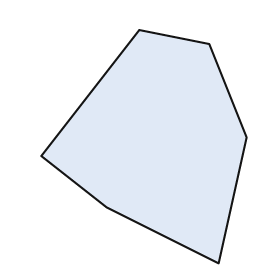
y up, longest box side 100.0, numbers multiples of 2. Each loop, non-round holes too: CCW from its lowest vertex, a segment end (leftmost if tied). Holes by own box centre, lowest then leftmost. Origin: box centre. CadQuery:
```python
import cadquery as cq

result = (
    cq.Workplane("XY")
    .moveTo(32.0, -50.0)
    .lineTo(44.0, 4.0)
    .lineTo(28.0, 44.0)
    .lineTo(-2.0, 50.0)
    .lineTo(-44.0, -4.0)
    .lineTo(-16.0, -26.0)
    .close()
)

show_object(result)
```